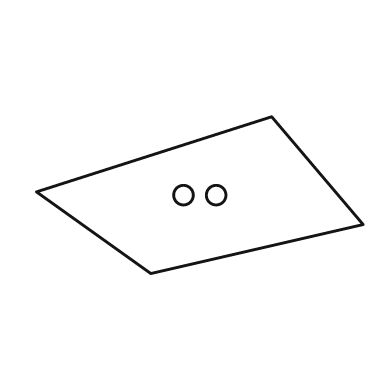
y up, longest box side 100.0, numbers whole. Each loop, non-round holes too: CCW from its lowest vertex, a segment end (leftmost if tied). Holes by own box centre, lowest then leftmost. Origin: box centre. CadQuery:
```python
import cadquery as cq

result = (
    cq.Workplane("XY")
    .moveTo(-15.0, -24.0)
    .lineTo(50.0, -9.0)
    .lineTo(22.0, 24.0)
    .lineTo(-50.0, 1.0)
    .close()
    .moveTo(-5.0, 0.0)
    .circle(3.0)
    .moveTo(5.0, 0.0)
    .circle(3.0)
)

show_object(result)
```